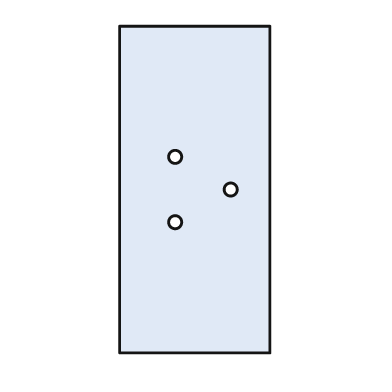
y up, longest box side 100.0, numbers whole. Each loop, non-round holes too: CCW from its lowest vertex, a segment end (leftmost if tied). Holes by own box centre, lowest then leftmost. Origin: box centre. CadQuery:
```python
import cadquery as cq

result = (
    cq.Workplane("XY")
    .moveTo(-23.0, -50.0)
    .lineTo(23.0, -50.0)
    .lineTo(23.0, 50.0)
    .lineTo(-23.0, 50.0)
    .close()
    .moveTo(-6.0, -10.0)
    .circle(2.0)
    .moveTo(11.0, 0.0)
    .circle(2.0)
    .moveTo(-6.0, 10.0)
    .circle(2.0)
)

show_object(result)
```